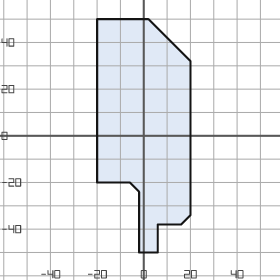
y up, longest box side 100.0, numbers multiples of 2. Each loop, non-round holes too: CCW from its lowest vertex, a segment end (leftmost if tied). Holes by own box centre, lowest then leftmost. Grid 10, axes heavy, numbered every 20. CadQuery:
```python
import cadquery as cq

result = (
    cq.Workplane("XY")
    .moveTo(-2.0, -50.0)
    .lineTo(6.0, -50.0)
    .lineTo(6.0, -38.0)
    .lineTo(16.0, -38.0)
    .lineTo(20.0, -34.0)
    .lineTo(20.0, 32.0)
    .lineTo(2.0, 50.0)
    .lineTo(-20.0, 50.0)
    .lineTo(-20.0, -20.0)
    .lineTo(-6.0, -20.0)
    .lineTo(-2.0, -24.0)
    .close()
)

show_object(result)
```